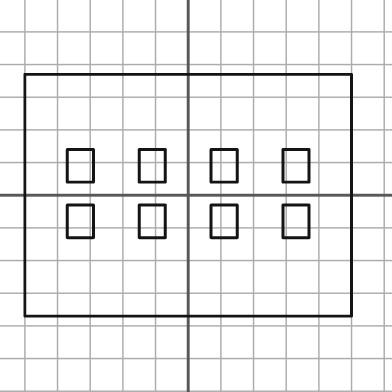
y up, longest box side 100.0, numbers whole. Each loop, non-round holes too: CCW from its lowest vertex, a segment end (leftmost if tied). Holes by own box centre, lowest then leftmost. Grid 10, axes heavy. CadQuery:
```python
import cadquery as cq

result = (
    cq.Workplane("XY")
    .moveTo(-50.0, -37.0)
    .lineTo(50.0, -37.0)
    .lineTo(50.0, 37.0)
    .lineTo(-50.0, 37.0)
    .close()
    .moveTo(-37.0, -13.0)
    .lineTo(-29.0, -13.0)
    .lineTo(-29.0, -3.0)
    .lineTo(-37.0, -3.0)
    .close()
    .moveTo(-15.0, -13.0)
    .lineTo(-7.0, -13.0)
    .lineTo(-7.0, -3.0)
    .lineTo(-15.0, -3.0)
    .close()
    .moveTo(7.0, -13.0)
    .lineTo(15.0, -13.0)
    .lineTo(15.0, -3.0)
    .lineTo(7.0, -3.0)
    .close()
    .moveTo(29.0, -13.0)
    .lineTo(37.0, -13.0)
    .lineTo(37.0, -3.0)
    .lineTo(29.0, -3.0)
    .close()
    .moveTo(-37.0, 4.0)
    .lineTo(-29.0, 4.0)
    .lineTo(-29.0, 14.0)
    .lineTo(-37.0, 14.0)
    .close()
    .moveTo(-15.0, 4.0)
    .lineTo(-7.0, 4.0)
    .lineTo(-7.0, 14.0)
    .lineTo(-15.0, 14.0)
    .close()
    .moveTo(7.0, 4.0)
    .lineTo(15.0, 4.0)
    .lineTo(15.0, 14.0)
    .lineTo(7.0, 14.0)
    .close()
    .moveTo(29.0, 4.0)
    .lineTo(37.0, 4.0)
    .lineTo(37.0, 14.0)
    .lineTo(29.0, 14.0)
    .close()
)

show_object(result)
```